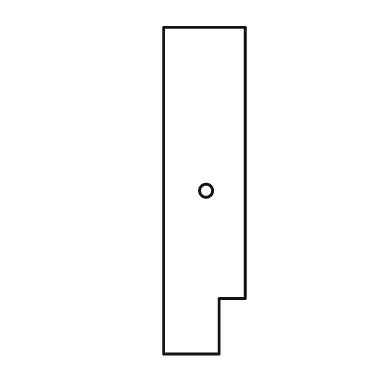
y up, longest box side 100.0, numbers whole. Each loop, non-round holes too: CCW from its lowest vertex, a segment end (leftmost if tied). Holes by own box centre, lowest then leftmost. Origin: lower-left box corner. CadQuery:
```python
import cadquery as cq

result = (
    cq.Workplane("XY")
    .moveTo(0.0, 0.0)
    .lineTo(17.0, 0.0)
    .lineTo(17.0, 17.0)
    .lineTo(25.0, 17.0)
    .lineTo(25.0, 100.0)
    .lineTo(0.0, 100.0)
    .close()
    .moveTo(13.0, 50.0)
    .circle(2.0)
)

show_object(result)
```